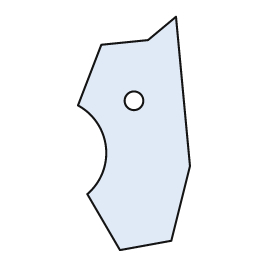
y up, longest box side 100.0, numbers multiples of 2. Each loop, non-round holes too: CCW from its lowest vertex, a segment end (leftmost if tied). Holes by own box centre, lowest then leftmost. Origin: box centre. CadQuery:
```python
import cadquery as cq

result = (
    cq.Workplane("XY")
    .moveTo(-6.0, -50.0)
    .lineTo(16.0, -46.0)
    .lineTo(24.0, -14.0)
    .lineTo(18.0, 50.0)
    .lineTo(6.0, 40.0)
    .lineTo(-14.0, 38.0)
    .lineTo(-24.0, 12.0)
    .threePointArc((-12.0, -6.0), (-20.0, -26.0))
    .close()
    .moveTo(0.0, 14.0)
    .circle(4.0)
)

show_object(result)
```